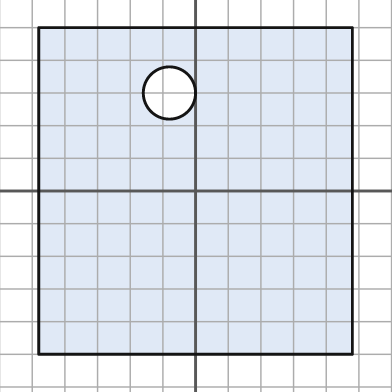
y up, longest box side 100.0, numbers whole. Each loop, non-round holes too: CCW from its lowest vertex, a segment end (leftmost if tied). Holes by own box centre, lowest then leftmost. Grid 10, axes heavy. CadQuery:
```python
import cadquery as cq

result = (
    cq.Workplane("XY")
    .moveTo(-48.0, -50.0)
    .lineTo(48.0, -50.0)
    .lineTo(48.0, 50.0)
    .lineTo(-48.0, 50.0)
    .close()
    .moveTo(-8.0, 30.0)
    .circle(8.0)
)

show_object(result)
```